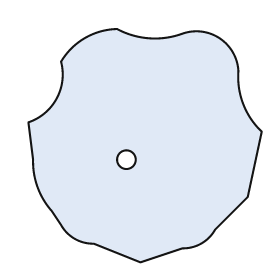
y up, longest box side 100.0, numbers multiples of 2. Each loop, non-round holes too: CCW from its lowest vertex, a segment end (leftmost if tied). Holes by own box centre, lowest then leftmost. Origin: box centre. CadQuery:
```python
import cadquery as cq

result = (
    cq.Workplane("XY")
    .moveTo(-2.0, -50.0)
    .lineTo(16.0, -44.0)
    .threePointArc((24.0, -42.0), (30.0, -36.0))
    .lineTo(44.0, -22.0)
    .lineTo(50.0, 6.0)
    .threePointArc((42.0, 18.0), (40.0, 32.0))
    .threePointArc((32.0, 46.0), (16.0, 48.0))
    .threePointArc((2.0, 46.0), (-12.0, 50.0))
    .threePointArc((-26.0, 46.0), (-36.0, 36.0))
    .threePointArc((-38.0, 20.0), (-50.0, 10.0))
    .lineTo(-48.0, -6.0)
    .threePointArc((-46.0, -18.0), (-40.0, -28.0))
    .lineTo(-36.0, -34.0)
    .threePointArc((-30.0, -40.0), (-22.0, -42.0))
    .close()
    .moveTo(-8.0, -6.0)
    .circle(4.0)
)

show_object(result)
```